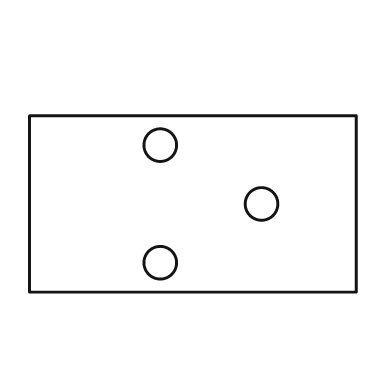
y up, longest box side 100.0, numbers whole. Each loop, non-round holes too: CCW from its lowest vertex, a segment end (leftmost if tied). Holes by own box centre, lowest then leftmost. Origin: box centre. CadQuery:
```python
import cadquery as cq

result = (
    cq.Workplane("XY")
    .moveTo(-50.0, -27.0)
    .lineTo(50.0, -27.0)
    .lineTo(50.0, 27.0)
    .lineTo(-50.0, 27.0)
    .close()
    .moveTo(-10.0, -18.0)
    .circle(5.0)
    .moveTo(21.0, 0.0)
    .circle(5.0)
    .moveTo(-10.0, 18.0)
    .circle(5.0)
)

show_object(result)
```